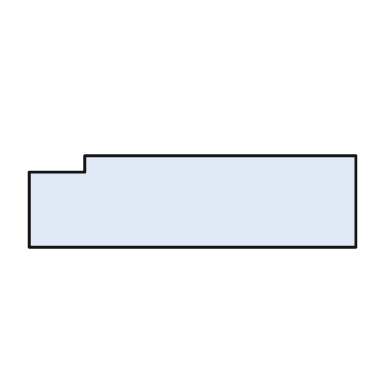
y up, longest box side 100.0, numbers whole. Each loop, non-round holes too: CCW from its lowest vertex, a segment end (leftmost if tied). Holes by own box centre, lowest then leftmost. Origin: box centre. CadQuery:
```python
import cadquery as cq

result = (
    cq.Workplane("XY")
    .moveTo(-50.0, -14.0)
    .lineTo(50.0, -14.0)
    .lineTo(50.0, 14.0)
    .lineTo(-33.0, 14.0)
    .lineTo(-33.0, 9.0)
    .lineTo(-50.0, 9.0)
    .close()
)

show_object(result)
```